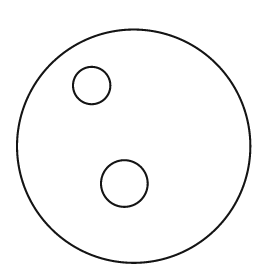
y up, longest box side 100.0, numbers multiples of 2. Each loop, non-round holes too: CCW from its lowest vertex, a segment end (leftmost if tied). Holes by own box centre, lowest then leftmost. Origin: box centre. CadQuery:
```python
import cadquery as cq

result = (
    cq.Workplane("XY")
    .moveTo(0.0, 0.0)
    .circle(50.0)
    .moveTo(-4.0, -16.0)
    .circle(10.0)
    .moveTo(-18.0, 26.0)
    .circle(8.0)
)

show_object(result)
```